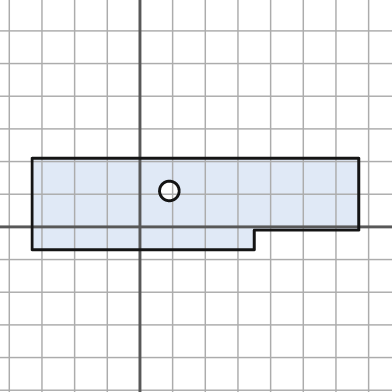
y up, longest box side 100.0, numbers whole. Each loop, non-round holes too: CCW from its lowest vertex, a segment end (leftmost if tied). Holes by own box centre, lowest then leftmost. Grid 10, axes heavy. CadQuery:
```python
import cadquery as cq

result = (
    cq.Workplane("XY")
    .moveTo(-33.0, -7.0)
    .lineTo(35.0, -7.0)
    .lineTo(35.0, -1.0)
    .lineTo(67.0, -1.0)
    .lineTo(67.0, 21.0)
    .lineTo(-33.0, 21.0)
    .close()
    .moveTo(9.0, 11.0)
    .circle(3.0)
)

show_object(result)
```